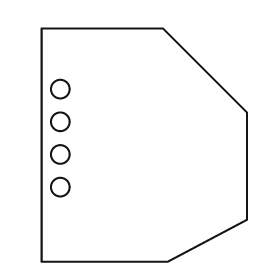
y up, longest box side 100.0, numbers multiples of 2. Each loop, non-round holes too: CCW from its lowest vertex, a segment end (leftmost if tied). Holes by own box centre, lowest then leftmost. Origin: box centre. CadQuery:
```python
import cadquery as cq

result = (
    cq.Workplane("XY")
    .moveTo(-44.0, -50.0)
    .lineTo(10.0, -50.0)
    .lineTo(44.0, -32.0)
    .lineTo(44.0, 14.0)
    .lineTo(8.0, 50.0)
    .lineTo(-44.0, 50.0)
    .close()
    .moveTo(-36.0, -18.0)
    .circle(4.0)
    .moveTo(-36.0, -4.0)
    .circle(4.0)
    .moveTo(-36.0, 10.0)
    .circle(4.0)
    .moveTo(-36.0, 24.0)
    .circle(4.0)
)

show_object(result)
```